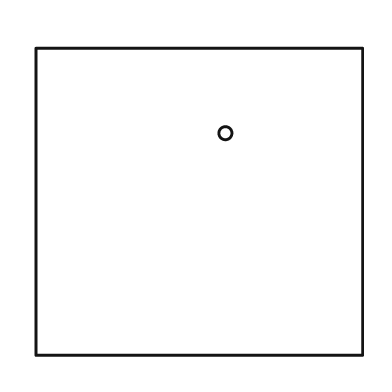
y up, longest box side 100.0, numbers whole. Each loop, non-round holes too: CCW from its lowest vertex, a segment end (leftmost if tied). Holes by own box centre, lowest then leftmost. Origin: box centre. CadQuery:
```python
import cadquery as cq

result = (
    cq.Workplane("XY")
    .moveTo(-50.0, -47.0)
    .lineTo(50.0, -47.0)
    .lineTo(50.0, 47.0)
    .lineTo(-50.0, 47.0)
    .close()
    .moveTo(8.0, 21.0)
    .circle(2.0)
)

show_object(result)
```